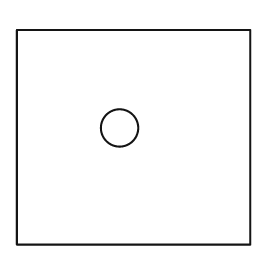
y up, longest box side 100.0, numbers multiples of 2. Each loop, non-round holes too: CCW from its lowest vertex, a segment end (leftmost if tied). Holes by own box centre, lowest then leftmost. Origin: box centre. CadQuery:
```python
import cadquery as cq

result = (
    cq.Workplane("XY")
    .moveTo(-50.0, -46.0)
    .lineTo(50.0, -46.0)
    .lineTo(50.0, 46.0)
    .lineTo(-50.0, 46.0)
    .close()
    .moveTo(-6.0, 4.0)
    .circle(8.0)
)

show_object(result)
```